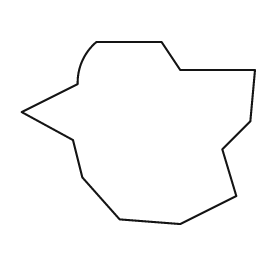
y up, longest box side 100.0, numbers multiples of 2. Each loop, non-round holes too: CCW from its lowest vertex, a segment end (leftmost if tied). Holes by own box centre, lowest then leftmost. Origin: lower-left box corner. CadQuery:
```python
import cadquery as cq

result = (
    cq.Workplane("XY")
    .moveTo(68.0, 0.0)
    .lineTo(92.0, 12.0)
    .lineTo(86.0, 32.0)
    .lineTo(98.0, 44.0)
    .lineTo(100.0, 66.0)
    .lineTo(68.0, 66.0)
    .lineTo(60.0, 78.0)
    .lineTo(32.0, 78.0)
    .threePointArc((26.0, 70.0), (24.0, 60.0))
    .lineTo(0.0, 48.0)
    .lineTo(22.0, 36.0)
    .lineTo(26.0, 20.0)
    .lineTo(42.0, 2.0)
    .close()
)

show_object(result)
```